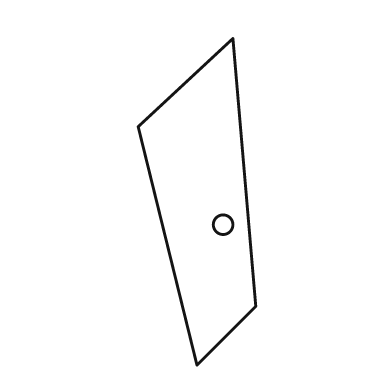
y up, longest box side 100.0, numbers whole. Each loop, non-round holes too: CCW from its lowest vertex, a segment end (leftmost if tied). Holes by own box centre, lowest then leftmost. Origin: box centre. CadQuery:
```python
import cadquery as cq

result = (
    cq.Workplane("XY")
    .moveTo(0.0, -50.0)
    .lineTo(18.0, -32.0)
    .lineTo(11.0, 50.0)
    .lineTo(-18.0, 23.0)
    .close()
    .moveTo(8.0, -7.0)
    .circle(3.0)
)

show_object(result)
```